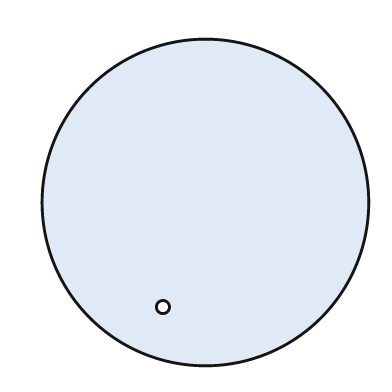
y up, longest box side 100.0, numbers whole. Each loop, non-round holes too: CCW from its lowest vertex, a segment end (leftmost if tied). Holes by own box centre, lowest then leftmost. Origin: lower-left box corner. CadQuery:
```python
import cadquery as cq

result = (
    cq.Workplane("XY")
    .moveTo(50.0, 50.0)
    .circle(50.0)
    .moveTo(37.0, 18.0)
    .circle(2.0)
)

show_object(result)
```